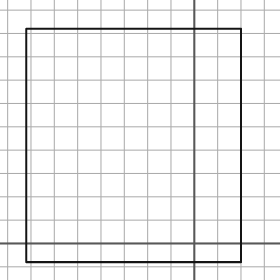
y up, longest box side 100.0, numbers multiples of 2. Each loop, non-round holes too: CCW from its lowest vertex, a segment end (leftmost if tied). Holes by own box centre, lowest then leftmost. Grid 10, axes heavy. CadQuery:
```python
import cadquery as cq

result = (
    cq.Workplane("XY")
    .moveTo(-72.0, -8.0)
    .lineTo(20.0, -8.0)
    .lineTo(20.0, 92.0)
    .lineTo(-72.0, 92.0)
    .close()
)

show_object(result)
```